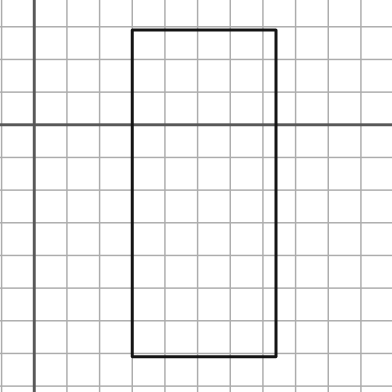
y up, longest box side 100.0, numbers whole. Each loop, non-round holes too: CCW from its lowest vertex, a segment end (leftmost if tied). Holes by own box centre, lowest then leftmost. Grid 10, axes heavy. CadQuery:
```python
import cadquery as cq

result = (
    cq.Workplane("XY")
    .moveTo(30.0, -71.0)
    .lineTo(74.0, -71.0)
    .lineTo(74.0, 29.0)
    .lineTo(30.0, 29.0)
    .close()
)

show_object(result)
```